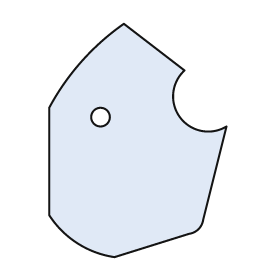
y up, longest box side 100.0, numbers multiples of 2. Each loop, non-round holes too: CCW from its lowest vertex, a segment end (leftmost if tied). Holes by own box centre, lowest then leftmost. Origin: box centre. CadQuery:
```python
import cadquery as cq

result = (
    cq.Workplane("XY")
    .moveTo(-10.0, -50.0)
    .lineTo(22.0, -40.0)
    .threePointArc((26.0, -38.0), (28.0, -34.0))
    .lineTo(38.0, 6.0)
    .threePointArc((18.0, 10.0), (20.0, 30.0))
    .lineTo(-6.0, 50.0)
    .threePointArc((-24.0, 34.0), (-38.0, 14.0))
    .lineTo(-38.0, -32.0)
    .threePointArc((-26.0, -44.0), (-10.0, -50.0))
    .close()
    .moveTo(-16.0, 10.0)
    .circle(4.0)
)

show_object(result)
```